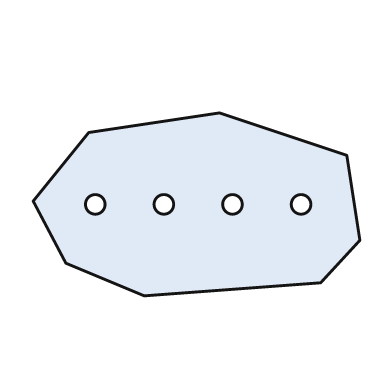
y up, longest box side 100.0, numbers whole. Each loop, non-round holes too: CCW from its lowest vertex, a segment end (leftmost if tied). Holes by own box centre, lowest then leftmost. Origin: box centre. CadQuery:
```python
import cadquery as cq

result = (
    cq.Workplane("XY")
    .moveTo(-16.0, -28.0)
    .lineTo(38.0, -24.0)
    .lineTo(50.0, -11.0)
    .lineTo(46.0, 15.0)
    .lineTo(7.0, 28.0)
    .lineTo(-33.0, 22.0)
    .lineTo(-50.0, 1.0)
    .lineTo(-40.0, -18.0)
    .close()
    .moveTo(-31.0, 0.0)
    .circle(3.0)
    .moveTo(-10.0, 0.0)
    .circle(3.0)
    .moveTo(11.0, 0.0)
    .circle(3.0)
    .moveTo(32.0, 0.0)
    .circle(3.0)
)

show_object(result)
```